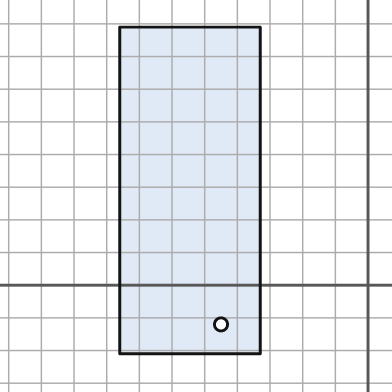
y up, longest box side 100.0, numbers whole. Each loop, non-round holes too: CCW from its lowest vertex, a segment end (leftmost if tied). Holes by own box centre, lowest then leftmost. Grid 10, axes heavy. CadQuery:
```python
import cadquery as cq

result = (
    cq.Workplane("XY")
    .moveTo(-76.0, -21.0)
    .lineTo(-33.0, -21.0)
    .lineTo(-33.0, 79.0)
    .lineTo(-76.0, 79.0)
    .close()
    .moveTo(-45.0, -12.0)
    .circle(2.0)
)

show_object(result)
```